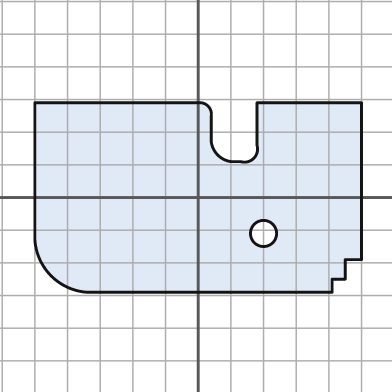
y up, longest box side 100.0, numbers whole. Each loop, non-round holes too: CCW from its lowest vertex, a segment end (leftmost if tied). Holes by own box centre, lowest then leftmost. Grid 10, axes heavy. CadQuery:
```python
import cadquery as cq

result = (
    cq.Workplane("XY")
    .moveTo(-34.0, -29.0)
    .lineTo(41.0, -29.0)
    .lineTo(41.0, -25.0)
    .lineTo(45.0, -25.0)
    .lineTo(45.0, -19.0)
    .lineTo(50.0, -19.0)
    .lineTo(50.0, 29.0)
    .lineTo(18.0, 29.0)
    .lineTo(18.0, 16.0)
    .threePointArc((17.0, 12.0), (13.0, 11.0))
    .lineTo(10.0, 11.0)
    .threePointArc((6.0, 13.0), (4.0, 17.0))
    .lineTo(4.0, 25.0)
    .threePointArc((3.0, 28.0), (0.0, 29.0))
    .lineTo(-50.0, 29.0)
    .lineTo(-50.0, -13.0)
    .threePointArc((-45.0, -24.0), (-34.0, -29.0))
    .close()
    .moveTo(20.0, -11.0)
    .circle(4.0)
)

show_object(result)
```